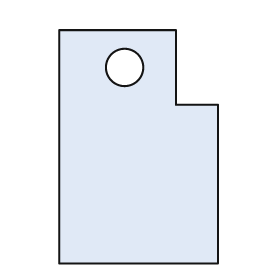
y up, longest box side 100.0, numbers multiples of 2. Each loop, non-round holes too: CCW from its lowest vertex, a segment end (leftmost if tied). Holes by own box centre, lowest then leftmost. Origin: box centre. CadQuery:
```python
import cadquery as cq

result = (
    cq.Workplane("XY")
    .moveTo(-34.0, -50.0)
    .lineTo(34.0, -50.0)
    .lineTo(34.0, 18.0)
    .lineTo(16.0, 18.0)
    .lineTo(16.0, 50.0)
    .lineTo(-34.0, 50.0)
    .close()
    .moveTo(-6.0, 34.0)
    .circle(8.0)
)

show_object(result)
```